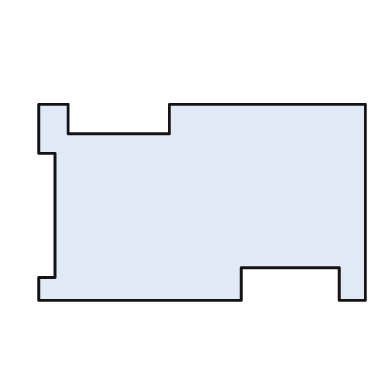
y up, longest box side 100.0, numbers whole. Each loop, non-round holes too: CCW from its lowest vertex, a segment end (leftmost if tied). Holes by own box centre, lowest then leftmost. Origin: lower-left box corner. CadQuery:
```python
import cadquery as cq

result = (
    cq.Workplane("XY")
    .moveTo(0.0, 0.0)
    .lineTo(62.0, 0.0)
    .lineTo(62.0, 10.0)
    .lineTo(92.0, 10.0)
    .lineTo(92.0, 0.0)
    .lineTo(100.0, 0.0)
    .lineTo(100.0, 60.0)
    .lineTo(40.0, 60.0)
    .lineTo(40.0, 51.0)
    .lineTo(9.0, 51.0)
    .lineTo(9.0, 60.0)
    .lineTo(0.0, 60.0)
    .lineTo(0.0, 45.0)
    .lineTo(5.0, 45.0)
    .lineTo(5.0, 7.0)
    .lineTo(0.0, 7.0)
    .close()
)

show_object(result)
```